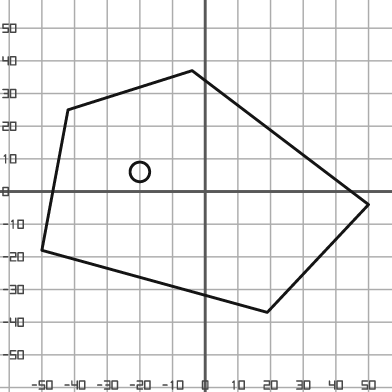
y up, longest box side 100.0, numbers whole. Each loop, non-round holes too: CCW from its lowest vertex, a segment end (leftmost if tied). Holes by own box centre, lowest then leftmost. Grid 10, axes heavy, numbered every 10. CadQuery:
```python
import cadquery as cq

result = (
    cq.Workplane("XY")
    .moveTo(19.0, -37.0)
    .lineTo(50.0, -4.0)
    .lineTo(-4.0, 37.0)
    .lineTo(-42.0, 25.0)
    .lineTo(-50.0, -18.0)
    .close()
    .moveTo(-20.0, 6.0)
    .circle(3.0)
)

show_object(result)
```